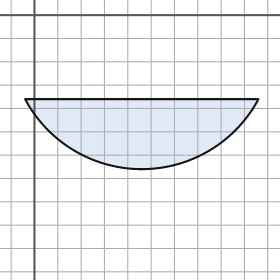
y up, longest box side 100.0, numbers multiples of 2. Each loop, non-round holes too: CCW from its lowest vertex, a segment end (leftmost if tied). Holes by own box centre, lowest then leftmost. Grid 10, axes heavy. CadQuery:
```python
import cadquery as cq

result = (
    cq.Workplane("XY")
    .moveTo(-4.0, -36.0)
    .threePointArc((46.0, -66.0), (96.0, -36.0))
    .close()
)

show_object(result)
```